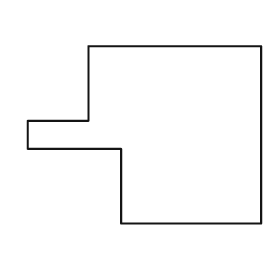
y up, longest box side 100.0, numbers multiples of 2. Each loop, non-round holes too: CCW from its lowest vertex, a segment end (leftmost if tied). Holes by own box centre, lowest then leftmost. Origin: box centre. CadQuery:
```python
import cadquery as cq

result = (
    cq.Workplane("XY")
    .moveTo(-10.0, -38.0)
    .lineTo(50.0, -38.0)
    .lineTo(50.0, 38.0)
    .lineTo(-24.0, 38.0)
    .lineTo(-24.0, 6.0)
    .lineTo(-50.0, 6.0)
    .lineTo(-50.0, -6.0)
    .lineTo(-10.0, -6.0)
    .close()
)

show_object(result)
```